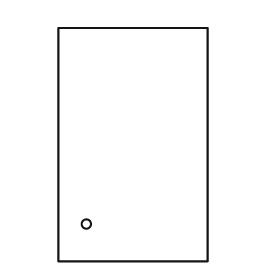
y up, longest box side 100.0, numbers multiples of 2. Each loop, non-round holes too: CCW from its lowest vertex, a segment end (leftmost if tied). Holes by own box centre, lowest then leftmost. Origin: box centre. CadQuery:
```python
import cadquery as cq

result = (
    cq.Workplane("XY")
    .moveTo(-32.0, -50.0)
    .lineTo(32.0, -50.0)
    .lineTo(32.0, 50.0)
    .lineTo(-32.0, 50.0)
    .close()
    .moveTo(-20.0, -34.0)
    .circle(2.0)
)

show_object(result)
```